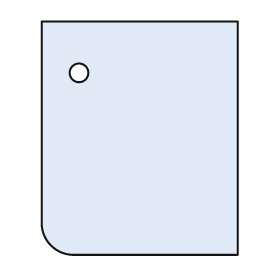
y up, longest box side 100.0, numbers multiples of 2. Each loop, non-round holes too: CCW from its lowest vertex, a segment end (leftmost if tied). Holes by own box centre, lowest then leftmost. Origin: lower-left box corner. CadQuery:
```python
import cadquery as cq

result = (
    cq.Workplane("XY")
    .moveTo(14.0, 0.0)
    .lineTo(84.0, 0.0)
    .lineTo(84.0, 100.0)
    .lineTo(0.0, 100.0)
    .lineTo(0.0, 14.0)
    .threePointArc((4.0, 4.0), (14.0, 0.0))
    .close()
    .moveTo(16.0, 78.0)
    .circle(4.0)
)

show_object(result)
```